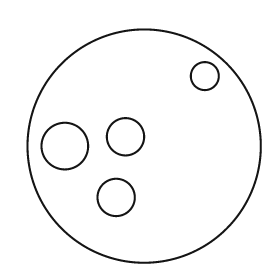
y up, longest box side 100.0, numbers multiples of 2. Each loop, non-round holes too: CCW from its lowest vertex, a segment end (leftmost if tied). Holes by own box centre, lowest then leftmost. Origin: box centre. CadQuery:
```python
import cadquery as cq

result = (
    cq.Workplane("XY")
    .moveTo(0.0, 0.0)
    .circle(50.0)
    .moveTo(-12.0, -22.0)
    .circle(8.0)
    .moveTo(-34.0, 0.0)
    .circle(10.0)
    .moveTo(-8.0, 4.0)
    .circle(8.0)
    .moveTo(26.0, 30.0)
    .circle(6.0)
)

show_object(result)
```